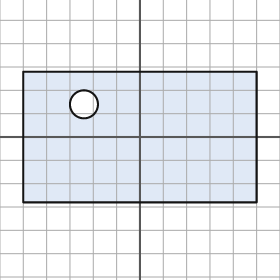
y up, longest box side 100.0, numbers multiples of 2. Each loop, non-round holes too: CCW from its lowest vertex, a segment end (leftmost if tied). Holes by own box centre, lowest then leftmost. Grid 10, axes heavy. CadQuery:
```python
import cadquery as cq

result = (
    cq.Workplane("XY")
    .moveTo(-50.0, -28.0)
    .lineTo(50.0, -28.0)
    .lineTo(50.0, 28.0)
    .lineTo(-50.0, 28.0)
    .close()
    .moveTo(-24.0, 14.0)
    .circle(6.0)
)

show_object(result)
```